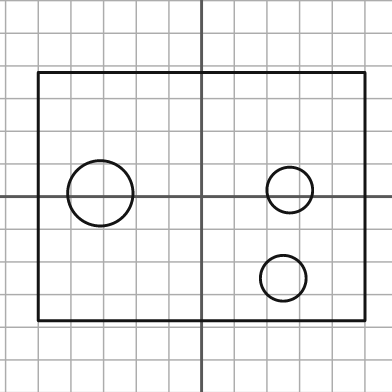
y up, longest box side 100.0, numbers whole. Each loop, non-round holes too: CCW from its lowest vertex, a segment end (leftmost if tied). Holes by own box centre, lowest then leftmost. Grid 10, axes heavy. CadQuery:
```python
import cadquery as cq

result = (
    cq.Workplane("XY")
    .moveTo(-50.0, -38.0)
    .lineTo(50.0, -38.0)
    .lineTo(50.0, 38.0)
    .lineTo(-50.0, 38.0)
    .close()
    .moveTo(25.0, -25.0)
    .circle(7.0)
    .moveTo(-31.0, 1.0)
    .circle(10.0)
    .moveTo(27.0, 2.0)
    .circle(7.0)
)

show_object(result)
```